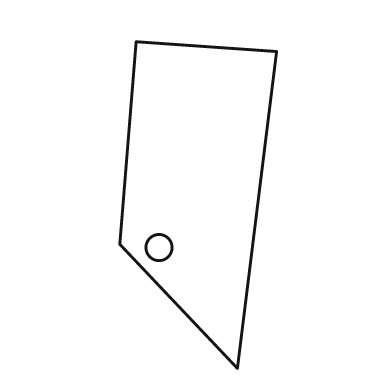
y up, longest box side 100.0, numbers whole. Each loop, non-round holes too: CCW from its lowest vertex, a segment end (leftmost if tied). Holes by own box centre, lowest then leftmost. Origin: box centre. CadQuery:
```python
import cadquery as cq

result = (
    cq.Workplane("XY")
    .moveTo(12.0, -50.0)
    .lineTo(24.0, 47.0)
    .lineTo(-19.0, 50.0)
    .lineTo(-24.0, -12.0)
    .close()
    .moveTo(-12.0, -13.0)
    .circle(4.0)
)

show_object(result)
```